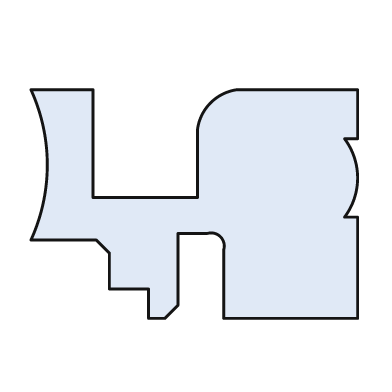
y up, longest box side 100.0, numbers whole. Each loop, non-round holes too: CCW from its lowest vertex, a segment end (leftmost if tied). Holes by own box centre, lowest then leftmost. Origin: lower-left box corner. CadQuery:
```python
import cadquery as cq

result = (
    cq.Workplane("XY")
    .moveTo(36.0, 0.0)
    .lineTo(41.0, 0.0)
    .lineTo(45.0, 4.0)
    .lineTo(45.0, 26.0)
    .lineTo(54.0, 26.0)
    .threePointArc((58.0, 25.0), (59.0, 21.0))
    .lineTo(59.0, 0.0)
    .lineTo(100.0, 0.0)
    .lineTo(100.0, 31.0)
    .lineTo(96.0, 31.0)
    .threePointArc((100.0, 43.0), (96.0, 55.0))
    .lineTo(100.0, 55.0)
    .lineTo(100.0, 70.0)
    .lineTo(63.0, 70.0)
    .threePointArc((55.0, 66.0), (51.0, 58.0))
    .lineTo(51.0, 37.0)
    .lineTo(19.0, 37.0)
    .lineTo(19.0, 70.0)
    .lineTo(0.0, 70.0)
    .threePointArc((5.0, 47.0), (0.0, 24.0))
    .lineTo(20.0, 24.0)
    .lineTo(24.0, 20.0)
    .lineTo(24.0, 9.0)
    .lineTo(36.0, 9.0)
    .close()
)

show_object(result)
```